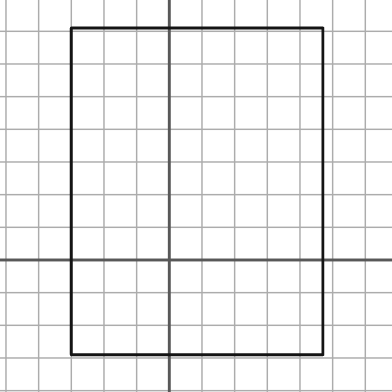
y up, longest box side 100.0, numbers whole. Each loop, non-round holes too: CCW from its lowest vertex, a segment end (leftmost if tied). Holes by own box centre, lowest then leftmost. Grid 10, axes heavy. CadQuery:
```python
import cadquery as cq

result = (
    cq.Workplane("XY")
    .moveTo(-30.0, -29.0)
    .lineTo(47.0, -29.0)
    .lineTo(47.0, 71.0)
    .lineTo(-30.0, 71.0)
    .close()
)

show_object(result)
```